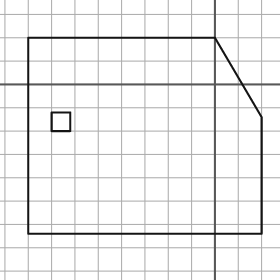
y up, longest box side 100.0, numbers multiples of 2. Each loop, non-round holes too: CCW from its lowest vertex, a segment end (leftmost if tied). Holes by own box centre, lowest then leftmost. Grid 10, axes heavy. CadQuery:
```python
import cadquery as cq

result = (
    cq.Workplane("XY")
    .moveTo(-80.0, -64.0)
    .lineTo(20.0, -64.0)
    .lineTo(20.0, -14.0)
    .lineTo(0.0, 20.0)
    .lineTo(-80.0, 20.0)
    .close()
    .moveTo(-70.0, -20.0)
    .lineTo(-62.0, -20.0)
    .lineTo(-62.0, -12.0)
    .lineTo(-70.0, -12.0)
    .close()
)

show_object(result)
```